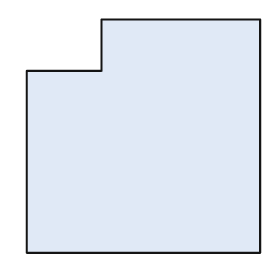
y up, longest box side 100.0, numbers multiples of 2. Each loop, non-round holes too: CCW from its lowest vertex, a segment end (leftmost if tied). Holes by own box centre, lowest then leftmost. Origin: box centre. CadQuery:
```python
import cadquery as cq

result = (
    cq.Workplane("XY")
    .moveTo(-50.0, -50.0)
    .lineTo(50.0, -50.0)
    .lineTo(50.0, 50.0)
    .lineTo(-18.0, 50.0)
    .lineTo(-18.0, 28.0)
    .lineTo(-50.0, 28.0)
    .close()
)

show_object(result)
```